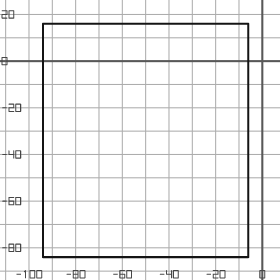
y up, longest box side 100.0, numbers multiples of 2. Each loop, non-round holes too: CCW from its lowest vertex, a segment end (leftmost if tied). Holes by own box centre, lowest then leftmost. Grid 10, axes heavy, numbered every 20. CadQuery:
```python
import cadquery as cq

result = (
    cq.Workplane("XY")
    .moveTo(-94.0, -84.0)
    .lineTo(-6.0, -84.0)
    .lineTo(-6.0, 16.0)
    .lineTo(-94.0, 16.0)
    .close()
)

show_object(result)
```